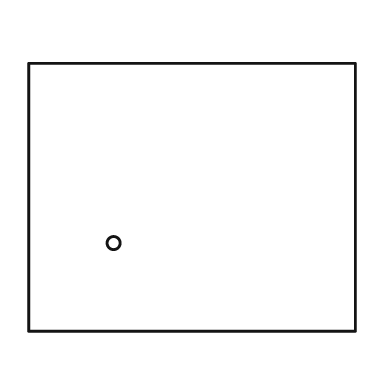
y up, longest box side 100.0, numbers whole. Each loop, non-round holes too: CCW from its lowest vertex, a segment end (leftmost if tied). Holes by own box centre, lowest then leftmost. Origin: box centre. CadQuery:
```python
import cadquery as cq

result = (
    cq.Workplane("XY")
    .moveTo(-50.0, -41.0)
    .lineTo(50.0, -41.0)
    .lineTo(50.0, 41.0)
    .lineTo(-50.0, 41.0)
    .close()
    .moveTo(-24.0, -14.0)
    .circle(2.0)
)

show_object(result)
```